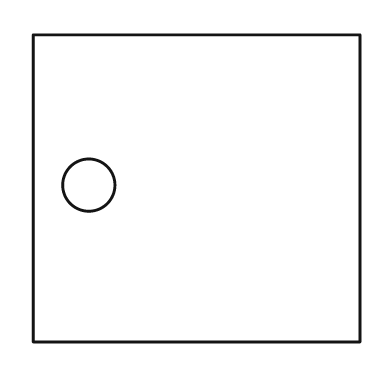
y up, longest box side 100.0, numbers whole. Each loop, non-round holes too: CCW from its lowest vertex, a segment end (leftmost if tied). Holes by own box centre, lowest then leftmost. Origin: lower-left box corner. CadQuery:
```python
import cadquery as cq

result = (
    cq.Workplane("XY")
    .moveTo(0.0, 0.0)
    .lineTo(100.0, 0.0)
    .lineTo(100.0, 94.0)
    .lineTo(0.0, 94.0)
    .close()
    .moveTo(17.0, 48.0)
    .circle(8.0)
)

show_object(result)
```